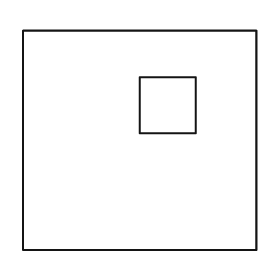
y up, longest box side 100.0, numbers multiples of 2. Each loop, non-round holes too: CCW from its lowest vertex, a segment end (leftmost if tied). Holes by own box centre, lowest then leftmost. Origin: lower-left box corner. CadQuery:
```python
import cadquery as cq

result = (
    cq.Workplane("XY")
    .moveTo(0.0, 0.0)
    .lineTo(100.0, 0.0)
    .lineTo(100.0, 94.0)
    .lineTo(0.0, 94.0)
    .close()
    .moveTo(50.0, 50.0)
    .lineTo(74.0, 50.0)
    .lineTo(74.0, 74.0)
    .lineTo(50.0, 74.0)
    .close()
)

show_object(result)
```